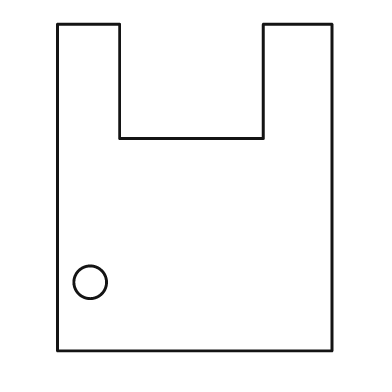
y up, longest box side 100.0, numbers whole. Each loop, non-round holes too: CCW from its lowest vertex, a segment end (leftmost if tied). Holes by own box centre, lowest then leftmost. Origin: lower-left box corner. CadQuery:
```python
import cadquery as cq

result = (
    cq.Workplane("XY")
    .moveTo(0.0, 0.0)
    .lineTo(84.0, 0.0)
    .lineTo(84.0, 100.0)
    .lineTo(63.0, 100.0)
    .lineTo(63.0, 65.0)
    .lineTo(19.0, 65.0)
    .lineTo(19.0, 100.0)
    .lineTo(0.0, 100.0)
    .close()
    .moveTo(10.0, 21.0)
    .circle(5.0)
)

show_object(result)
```